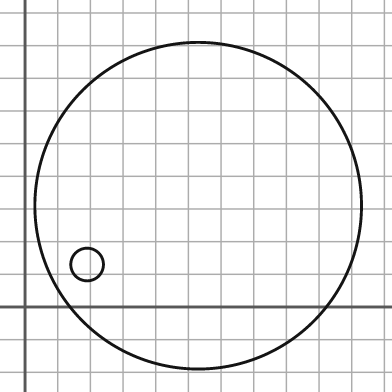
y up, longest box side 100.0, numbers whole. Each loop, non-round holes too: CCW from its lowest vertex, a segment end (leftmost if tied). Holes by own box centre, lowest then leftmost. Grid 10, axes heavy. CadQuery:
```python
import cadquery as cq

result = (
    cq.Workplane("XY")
    .moveTo(53.0, 31.0)
    .circle(50.0)
    .moveTo(19.0, 13.0)
    .circle(5.0)
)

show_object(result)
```